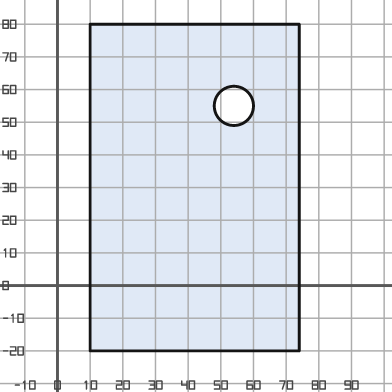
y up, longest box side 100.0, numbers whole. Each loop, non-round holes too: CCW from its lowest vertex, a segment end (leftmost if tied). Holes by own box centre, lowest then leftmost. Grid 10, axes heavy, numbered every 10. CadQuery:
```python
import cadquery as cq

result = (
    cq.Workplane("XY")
    .moveTo(10.0, -20.0)
    .lineTo(74.0, -20.0)
    .lineTo(74.0, 80.0)
    .lineTo(10.0, 80.0)
    .close()
    .moveTo(54.0, 55.0)
    .circle(6.0)
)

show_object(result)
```